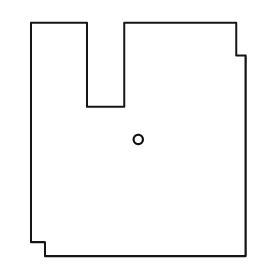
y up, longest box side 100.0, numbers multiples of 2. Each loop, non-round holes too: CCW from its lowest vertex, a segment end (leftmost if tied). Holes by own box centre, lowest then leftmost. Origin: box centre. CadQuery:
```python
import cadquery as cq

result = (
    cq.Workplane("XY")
    .moveTo(-40.0, -50.0)
    .lineTo(46.0, -50.0)
    .lineTo(46.0, 36.0)
    .lineTo(42.0, 36.0)
    .lineTo(42.0, 50.0)
    .lineTo(-6.0, 50.0)
    .lineTo(-6.0, 14.0)
    .lineTo(-22.0, 14.0)
    .lineTo(-22.0, 50.0)
    .lineTo(-46.0, 50.0)
    .lineTo(-46.0, -44.0)
    .lineTo(-40.0, -44.0)
    .close()
    .moveTo(0.0, 0.0)
    .circle(2.0)
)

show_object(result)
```